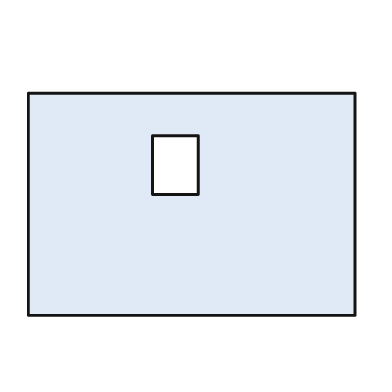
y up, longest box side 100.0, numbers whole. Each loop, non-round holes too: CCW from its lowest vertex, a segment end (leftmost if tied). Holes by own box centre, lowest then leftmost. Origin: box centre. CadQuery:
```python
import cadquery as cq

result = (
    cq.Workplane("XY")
    .moveTo(-50.0, -34.0)
    .lineTo(50.0, -34.0)
    .lineTo(50.0, 34.0)
    .lineTo(-50.0, 34.0)
    .close()
    .moveTo(-12.0, 3.0)
    .lineTo(2.0, 3.0)
    .lineTo(2.0, 21.0)
    .lineTo(-12.0, 21.0)
    .close()
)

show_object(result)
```